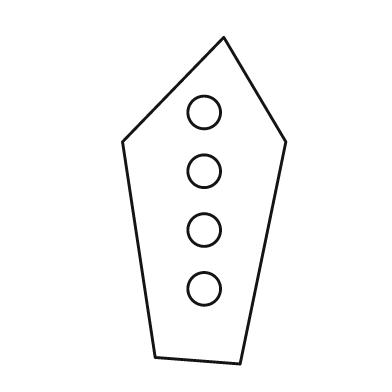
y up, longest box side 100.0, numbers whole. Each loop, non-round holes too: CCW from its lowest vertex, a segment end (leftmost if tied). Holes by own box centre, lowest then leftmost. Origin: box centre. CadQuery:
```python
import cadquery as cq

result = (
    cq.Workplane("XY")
    .moveTo(11.0, -50.0)
    .lineTo(25.0, 18.0)
    .lineTo(6.0, 50.0)
    .lineTo(-25.0, 18.0)
    .lineTo(-15.0, -48.0)
    .close()
    .moveTo(0.0, -27.0)
    .circle(5.0)
    .moveTo(0.0, -9.0)
    .circle(5.0)
    .moveTo(0.0, 9.0)
    .circle(5.0)
    .moveTo(0.0, 27.0)
    .circle(5.0)
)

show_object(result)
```